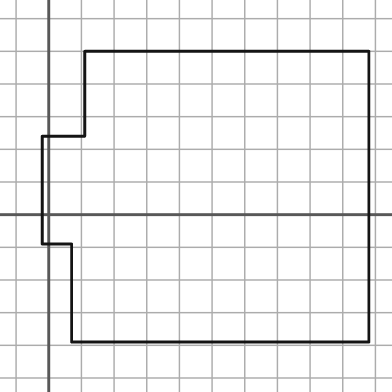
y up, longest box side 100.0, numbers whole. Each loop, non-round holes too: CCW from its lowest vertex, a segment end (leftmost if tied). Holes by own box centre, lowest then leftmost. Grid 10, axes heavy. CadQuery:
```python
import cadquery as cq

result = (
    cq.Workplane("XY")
    .moveTo(7.0, -39.0)
    .lineTo(98.0, -39.0)
    .lineTo(98.0, 50.0)
    .lineTo(11.0, 50.0)
    .lineTo(11.0, 24.0)
    .lineTo(-2.0, 24.0)
    .lineTo(-2.0, -9.0)
    .lineTo(7.0, -9.0)
    .close()
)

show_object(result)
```